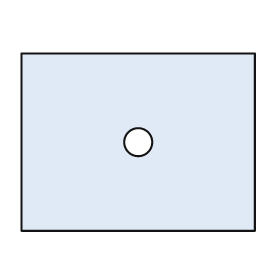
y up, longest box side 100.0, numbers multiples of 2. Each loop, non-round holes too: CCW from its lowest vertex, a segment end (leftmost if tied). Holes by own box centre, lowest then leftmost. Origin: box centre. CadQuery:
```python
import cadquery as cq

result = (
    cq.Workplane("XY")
    .moveTo(-50.0, -38.0)
    .lineTo(50.0, -38.0)
    .lineTo(50.0, 38.0)
    .lineTo(-50.0, 38.0)
    .close()
    .moveTo(0.0, 0.0)
    .circle(6.0)
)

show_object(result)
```